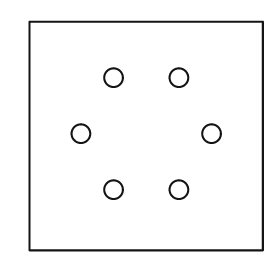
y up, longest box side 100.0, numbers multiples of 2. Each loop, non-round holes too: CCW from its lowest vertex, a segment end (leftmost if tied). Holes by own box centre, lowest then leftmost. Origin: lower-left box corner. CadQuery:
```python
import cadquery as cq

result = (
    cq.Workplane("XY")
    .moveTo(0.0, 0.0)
    .lineTo(100.0, 0.0)
    .lineTo(100.0, 98.0)
    .lineTo(0.0, 98.0)
    .close()
    .moveTo(36.0, 26.0)
    .circle(4.0)
    .moveTo(64.0, 26.0)
    .circle(4.0)
    .moveTo(22.0, 50.0)
    .circle(4.0)
    .moveTo(78.0, 50.0)
    .circle(4.0)
    .moveTo(36.0, 74.0)
    .circle(4.0)
    .moveTo(64.0, 74.0)
    .circle(4.0)
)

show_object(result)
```